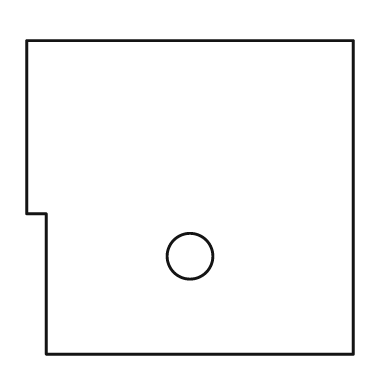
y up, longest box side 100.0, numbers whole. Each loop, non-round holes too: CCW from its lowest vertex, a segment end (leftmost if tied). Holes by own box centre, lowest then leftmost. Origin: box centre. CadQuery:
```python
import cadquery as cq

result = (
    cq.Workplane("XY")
    .moveTo(-44.0, -48.0)
    .lineTo(50.0, -48.0)
    .lineTo(50.0, 48.0)
    .lineTo(-50.0, 48.0)
    .lineTo(-50.0, -5.0)
    .lineTo(-44.0, -5.0)
    .close()
    .moveTo(0.0, -18.0)
    .circle(7.0)
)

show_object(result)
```